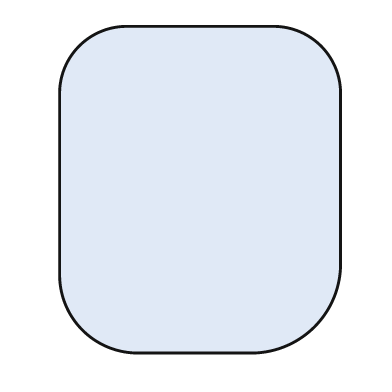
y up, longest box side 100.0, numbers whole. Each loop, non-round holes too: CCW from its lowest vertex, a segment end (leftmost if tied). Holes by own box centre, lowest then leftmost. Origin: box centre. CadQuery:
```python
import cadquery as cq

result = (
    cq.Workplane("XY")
    .moveTo(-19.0, -50.0)
    .lineTo(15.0, -50.0)
    .threePointArc((35.0, -42.0), (43.0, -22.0))
    .lineTo(43.0, 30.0)
    .threePointArc((37.0, 44.0), (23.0, 50.0))
    .lineTo(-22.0, 50.0)
    .threePointArc((-37.0, 44.0), (-43.0, 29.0))
    .lineTo(-43.0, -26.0)
    .threePointArc((-36.0, -43.0), (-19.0, -50.0))
    .close()
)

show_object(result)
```